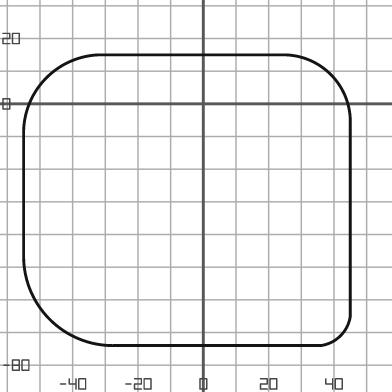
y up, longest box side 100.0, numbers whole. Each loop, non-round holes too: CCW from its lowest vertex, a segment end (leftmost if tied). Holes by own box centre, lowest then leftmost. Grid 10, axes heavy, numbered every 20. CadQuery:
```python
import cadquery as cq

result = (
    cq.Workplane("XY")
    .moveTo(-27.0, -74.0)
    .lineTo(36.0, -74.0)
    .threePointArc((42.0, -71.0), (45.0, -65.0))
    .lineTo(45.0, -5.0)
    .threePointArc((39.0, 9.0), (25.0, 15.0))
    .lineTo(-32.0, 15.0)
    .threePointArc((-48.0, 8.0), (-55.0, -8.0))
    .lineTo(-55.0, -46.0)
    .threePointArc((-47.0, -66.0), (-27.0, -74.0))
    .close()
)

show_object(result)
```